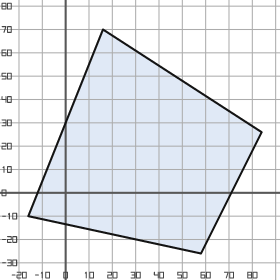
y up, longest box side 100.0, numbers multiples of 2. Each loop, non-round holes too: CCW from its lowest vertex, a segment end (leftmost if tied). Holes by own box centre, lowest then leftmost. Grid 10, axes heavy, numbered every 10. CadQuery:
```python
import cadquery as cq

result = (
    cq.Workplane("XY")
    .moveTo(58.0, -26.0)
    .lineTo(84.0, 26.0)
    .lineTo(16.0, 70.0)
    .lineTo(-16.0, -10.0)
    .close()
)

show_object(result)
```